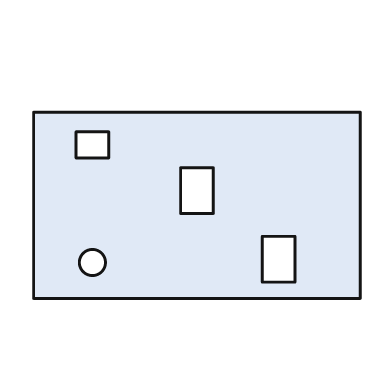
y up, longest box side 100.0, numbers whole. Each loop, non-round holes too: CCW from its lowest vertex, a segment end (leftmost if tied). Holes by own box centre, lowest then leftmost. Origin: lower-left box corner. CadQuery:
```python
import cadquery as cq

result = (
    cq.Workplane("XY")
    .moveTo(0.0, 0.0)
    .lineTo(100.0, 0.0)
    .lineTo(100.0, 57.0)
    .lineTo(0.0, 57.0)
    .close()
    .moveTo(18.0, 11.0)
    .circle(4.0)
    .moveTo(70.0, 5.0)
    .lineTo(80.0, 5.0)
    .lineTo(80.0, 19.0)
    .lineTo(70.0, 19.0)
    .close()
    .moveTo(45.0, 26.0)
    .lineTo(55.0, 26.0)
    .lineTo(55.0, 40.0)
    .lineTo(45.0, 40.0)
    .close()
    .moveTo(13.0, 43.0)
    .lineTo(23.0, 43.0)
    .lineTo(23.0, 51.0)
    .lineTo(13.0, 51.0)
    .close()
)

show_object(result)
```